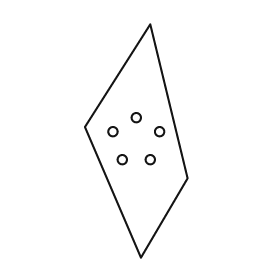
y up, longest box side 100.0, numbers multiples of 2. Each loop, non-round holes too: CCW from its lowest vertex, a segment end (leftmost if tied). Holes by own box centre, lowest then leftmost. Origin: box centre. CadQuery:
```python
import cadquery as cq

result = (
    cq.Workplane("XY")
    .moveTo(2.0, -50.0)
    .lineTo(22.0, -16.0)
    .lineTo(6.0, 50.0)
    .lineTo(-22.0, 6.0)
    .close()
    .moveTo(-6.0, -8.0)
    .circle(2.0)
    .moveTo(6.0, -8.0)
    .circle(2.0)
    .moveTo(-10.0, 4.0)
    .circle(2.0)
    .moveTo(10.0, 4.0)
    .circle(2.0)
    .moveTo(0.0, 10.0)
    .circle(2.0)
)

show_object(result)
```